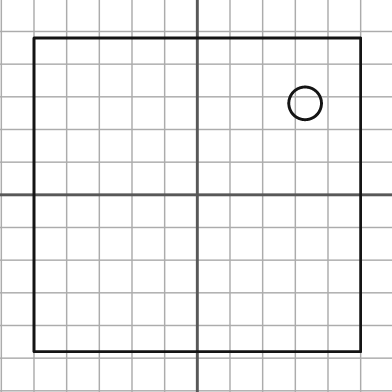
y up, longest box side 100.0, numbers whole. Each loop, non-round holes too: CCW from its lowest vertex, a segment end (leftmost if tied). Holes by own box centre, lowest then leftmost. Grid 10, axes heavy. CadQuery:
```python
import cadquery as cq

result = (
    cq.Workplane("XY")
    .moveTo(-50.0, -48.0)
    .lineTo(50.0, -48.0)
    .lineTo(50.0, 48.0)
    .lineTo(-50.0, 48.0)
    .close()
    .moveTo(33.0, 28.0)
    .circle(5.0)
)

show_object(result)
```